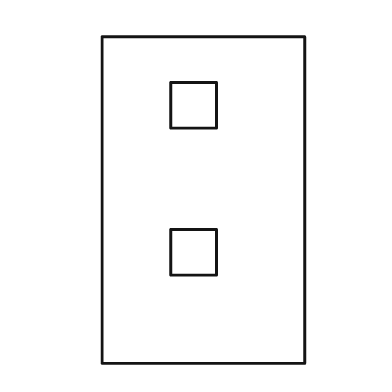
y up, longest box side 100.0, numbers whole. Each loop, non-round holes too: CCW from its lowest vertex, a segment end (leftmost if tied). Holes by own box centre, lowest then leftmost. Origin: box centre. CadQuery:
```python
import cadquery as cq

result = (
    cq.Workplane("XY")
    .moveTo(-31.0, -50.0)
    .lineTo(31.0, -50.0)
    .lineTo(31.0, 50.0)
    .lineTo(-31.0, 50.0)
    .close()
    .moveTo(-10.0, -23.0)
    .lineTo(4.0, -23.0)
    .lineTo(4.0, -9.0)
    .lineTo(-10.0, -9.0)
    .close()
    .moveTo(-10.0, 22.0)
    .lineTo(4.0, 22.0)
    .lineTo(4.0, 36.0)
    .lineTo(-10.0, 36.0)
    .close()
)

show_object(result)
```